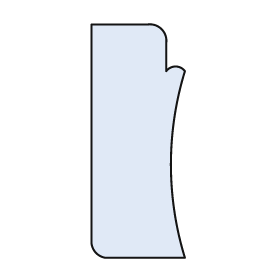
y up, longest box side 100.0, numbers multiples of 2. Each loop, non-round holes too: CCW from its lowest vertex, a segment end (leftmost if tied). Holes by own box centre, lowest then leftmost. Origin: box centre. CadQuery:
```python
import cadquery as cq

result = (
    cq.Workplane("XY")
    .moveTo(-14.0, -50.0)
    .lineTo(20.0, -50.0)
    .threePointArc((14.0, -10.0), (20.0, 30.0))
    .threePointArc((16.0, 32.0), (12.0, 30.0))
    .lineTo(12.0, 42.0)
    .threePointArc((10.0, 48.0), (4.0, 50.0))
    .lineTo(-20.0, 50.0)
    .lineTo(-20.0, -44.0)
    .threePointArc((-18.0, -48.0), (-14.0, -50.0))
    .close()
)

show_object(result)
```